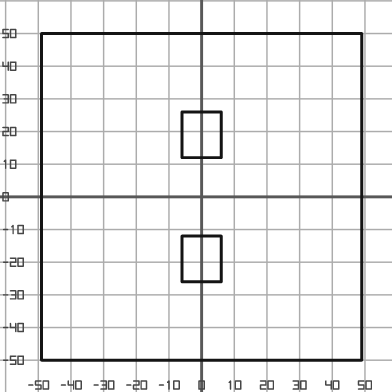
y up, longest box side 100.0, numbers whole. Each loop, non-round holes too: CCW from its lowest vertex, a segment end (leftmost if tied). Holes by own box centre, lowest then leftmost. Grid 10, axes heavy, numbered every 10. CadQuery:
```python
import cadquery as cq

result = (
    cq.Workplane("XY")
    .moveTo(-49.0, -50.0)
    .lineTo(49.0, -50.0)
    .lineTo(49.0, 50.0)
    .lineTo(-49.0, 50.0)
    .close()
    .moveTo(-6.0, -26.0)
    .lineTo(6.0, -26.0)
    .lineTo(6.0, -12.0)
    .lineTo(-6.0, -12.0)
    .close()
    .moveTo(-6.0, 12.0)
    .lineTo(6.0, 12.0)
    .lineTo(6.0, 26.0)
    .lineTo(-6.0, 26.0)
    .close()
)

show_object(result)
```